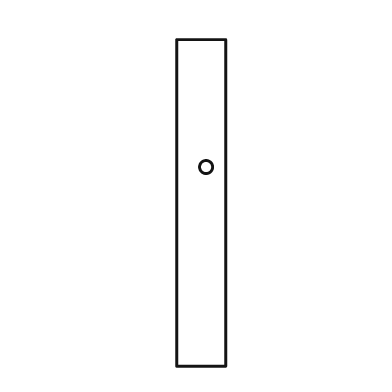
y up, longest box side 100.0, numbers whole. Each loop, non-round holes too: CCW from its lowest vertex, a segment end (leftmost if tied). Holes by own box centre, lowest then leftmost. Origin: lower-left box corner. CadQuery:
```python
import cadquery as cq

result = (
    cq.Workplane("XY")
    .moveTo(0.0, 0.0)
    .lineTo(15.0, 0.0)
    .lineTo(15.0, 100.0)
    .lineTo(0.0, 100.0)
    .close()
    .moveTo(9.0, 61.0)
    .circle(2.0)
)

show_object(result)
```